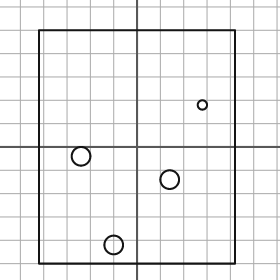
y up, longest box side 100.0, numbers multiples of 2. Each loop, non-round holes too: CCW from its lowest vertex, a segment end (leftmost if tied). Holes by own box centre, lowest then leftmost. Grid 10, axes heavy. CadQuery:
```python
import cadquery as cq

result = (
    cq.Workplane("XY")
    .moveTo(-42.0, -50.0)
    .lineTo(42.0, -50.0)
    .lineTo(42.0, 50.0)
    .lineTo(-42.0, 50.0)
    .close()
    .moveTo(-10.0, -42.0)
    .circle(4.0)
    .moveTo(14.0, -14.0)
    .circle(4.0)
    .moveTo(-24.0, -4.0)
    .circle(4.0)
    .moveTo(28.0, 18.0)
    .circle(2.0)
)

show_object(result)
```